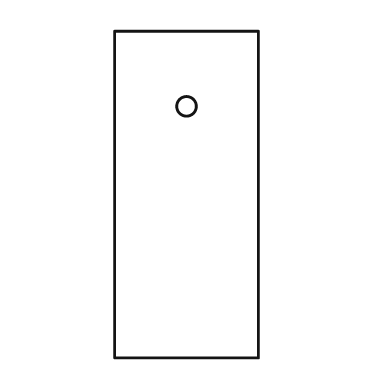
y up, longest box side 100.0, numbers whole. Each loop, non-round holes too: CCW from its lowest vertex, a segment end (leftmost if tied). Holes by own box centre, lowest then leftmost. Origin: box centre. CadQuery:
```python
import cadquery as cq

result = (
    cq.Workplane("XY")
    .moveTo(-22.0, -50.0)
    .lineTo(22.0, -50.0)
    .lineTo(22.0, 50.0)
    .lineTo(-22.0, 50.0)
    .close()
    .moveTo(0.0, 27.0)
    .circle(3.0)
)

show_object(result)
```